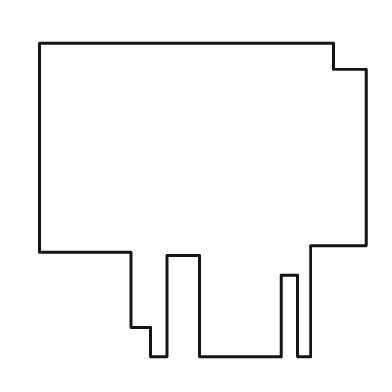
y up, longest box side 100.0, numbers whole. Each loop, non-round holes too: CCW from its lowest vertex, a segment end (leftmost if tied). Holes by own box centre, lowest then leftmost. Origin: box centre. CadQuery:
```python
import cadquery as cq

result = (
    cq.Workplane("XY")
    .moveTo(-16.0, -48.0)
    .lineTo(-11.0, -48.0)
    .lineTo(-11.0, -17.0)
    .lineTo(-1.0, -17.0)
    .lineTo(-1.0, -48.0)
    .lineTo(24.0, -48.0)
    .lineTo(24.0, -23.0)
    .lineTo(29.0, -23.0)
    .lineTo(29.0, -48.0)
    .lineTo(33.0, -48.0)
    .lineTo(33.0, -14.0)
    .lineTo(50.0, -14.0)
    .lineTo(50.0, 40.0)
    .lineTo(40.0, 40.0)
    .lineTo(40.0, 48.0)
    .lineTo(-50.0, 48.0)
    .lineTo(-50.0, -16.0)
    .lineTo(-22.0, -16.0)
    .lineTo(-22.0, -39.0)
    .lineTo(-16.0, -39.0)
    .close()
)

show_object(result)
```